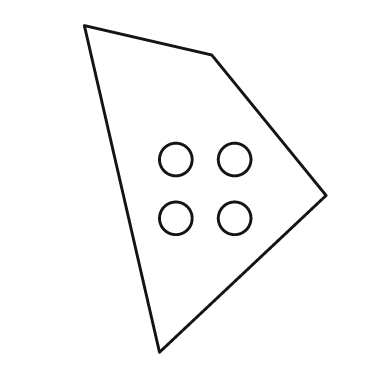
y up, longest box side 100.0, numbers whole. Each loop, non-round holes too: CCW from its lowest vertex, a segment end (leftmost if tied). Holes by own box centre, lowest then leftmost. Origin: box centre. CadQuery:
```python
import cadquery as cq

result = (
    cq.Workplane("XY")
    .moveTo(-14.0, -50.0)
    .lineTo(37.0, -2.0)
    .lineTo(2.0, 41.0)
    .lineTo(-37.0, 50.0)
    .close()
    .moveTo(-9.0, -9.0)
    .circle(5.0)
    .moveTo(9.0, -9.0)
    .circle(5.0)
    .moveTo(-9.0, 9.0)
    .circle(5.0)
    .moveTo(9.0, 9.0)
    .circle(5.0)
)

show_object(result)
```